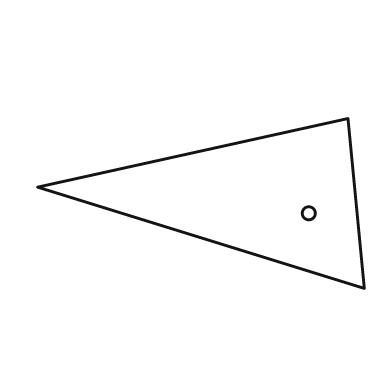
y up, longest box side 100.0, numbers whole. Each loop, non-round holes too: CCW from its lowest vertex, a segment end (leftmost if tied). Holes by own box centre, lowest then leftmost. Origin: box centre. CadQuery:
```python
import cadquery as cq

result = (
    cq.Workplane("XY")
    .moveTo(50.0, -26.0)
    .lineTo(45.0, 26.0)
    .lineTo(-50.0, 5.0)
    .close()
    .moveTo(33.0, -3.0)
    .circle(2.0)
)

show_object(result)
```